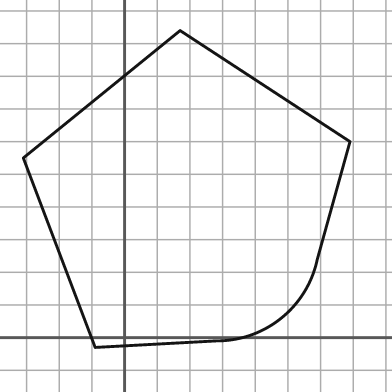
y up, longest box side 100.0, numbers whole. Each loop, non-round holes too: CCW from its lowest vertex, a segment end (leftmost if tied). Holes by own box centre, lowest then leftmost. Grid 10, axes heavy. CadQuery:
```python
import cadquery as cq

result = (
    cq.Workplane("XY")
    .moveTo(-9.0, -3.0)
    .lineTo(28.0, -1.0)
    .threePointArc((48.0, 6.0), (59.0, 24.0))
    .lineTo(69.0, 60.0)
    .lineTo(17.0, 94.0)
    .lineTo(-31.0, 55.0)
    .close()
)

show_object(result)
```